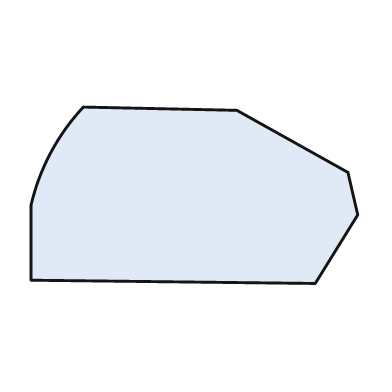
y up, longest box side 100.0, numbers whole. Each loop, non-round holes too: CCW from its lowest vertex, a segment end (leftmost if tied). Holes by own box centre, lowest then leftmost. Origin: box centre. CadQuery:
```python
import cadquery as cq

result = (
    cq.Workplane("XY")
    .moveTo(37.0, -27.0)
    .lineTo(50.0, -6.0)
    .lineTo(47.0, 7.0)
    .lineTo(13.0, 26.0)
    .lineTo(-34.0, 27.0)
    .threePointArc((-44.0, 13.0), (-50.0, -3.0))
    .lineTo(-50.0, -26.0)
    .close()
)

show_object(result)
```